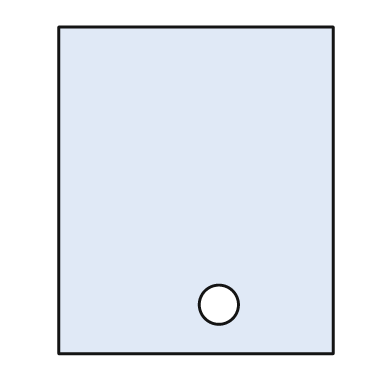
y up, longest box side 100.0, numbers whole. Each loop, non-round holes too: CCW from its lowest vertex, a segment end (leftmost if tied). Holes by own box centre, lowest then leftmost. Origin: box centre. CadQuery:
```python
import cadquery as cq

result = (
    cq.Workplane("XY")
    .moveTo(-42.0, -50.0)
    .lineTo(42.0, -50.0)
    .lineTo(42.0, 50.0)
    .lineTo(-42.0, 50.0)
    .close()
    .moveTo(7.0, -35.0)
    .circle(6.0)
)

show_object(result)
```